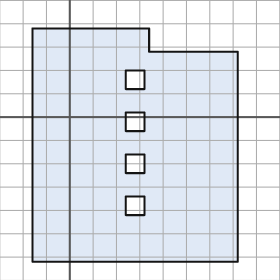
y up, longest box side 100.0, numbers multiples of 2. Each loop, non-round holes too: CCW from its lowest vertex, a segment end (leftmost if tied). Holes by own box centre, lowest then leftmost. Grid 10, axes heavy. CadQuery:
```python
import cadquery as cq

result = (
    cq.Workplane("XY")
    .moveTo(-16.0, -62.0)
    .lineTo(72.0, -62.0)
    .lineTo(72.0, 28.0)
    .lineTo(34.0, 28.0)
    .lineTo(34.0, 38.0)
    .lineTo(-16.0, 38.0)
    .close()
    .moveTo(24.0, -42.0)
    .lineTo(32.0, -42.0)
    .lineTo(32.0, -34.0)
    .lineTo(24.0, -34.0)
    .close()
    .moveTo(24.0, -24.0)
    .lineTo(32.0, -24.0)
    .lineTo(32.0, -16.0)
    .lineTo(24.0, -16.0)
    .close()
    .moveTo(24.0, -6.0)
    .lineTo(32.0, -6.0)
    .lineTo(32.0, 2.0)
    .lineTo(24.0, 2.0)
    .close()
    .moveTo(24.0, 12.0)
    .lineTo(32.0, 12.0)
    .lineTo(32.0, 20.0)
    .lineTo(24.0, 20.0)
    .close()
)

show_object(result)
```